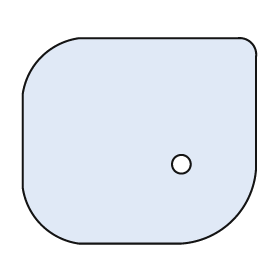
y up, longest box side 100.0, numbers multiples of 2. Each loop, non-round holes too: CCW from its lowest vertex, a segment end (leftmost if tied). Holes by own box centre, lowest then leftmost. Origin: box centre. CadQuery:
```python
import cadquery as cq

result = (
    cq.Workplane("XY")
    .moveTo(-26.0, -44.0)
    .lineTo(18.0, -44.0)
    .threePointArc((40.0, -34.0), (50.0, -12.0))
    .lineTo(50.0, 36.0)
    .threePointArc((48.0, 42.0), (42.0, 44.0))
    .lineTo(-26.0, 44.0)
    .threePointArc((-42.0, 36.0), (-50.0, 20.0))
    .lineTo(-50.0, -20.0)
    .threePointArc((-42.0, -36.0), (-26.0, -44.0))
    .close()
    .moveTo(18.0, -10.0)
    .circle(4.0)
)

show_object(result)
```